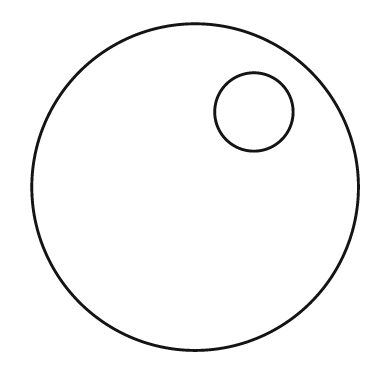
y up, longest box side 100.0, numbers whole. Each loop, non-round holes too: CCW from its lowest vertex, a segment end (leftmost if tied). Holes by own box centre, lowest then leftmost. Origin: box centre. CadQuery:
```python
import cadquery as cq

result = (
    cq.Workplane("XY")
    .moveTo(0.0, 0.0)
    .circle(50.0)
    .moveTo(18.0, 23.0)
    .circle(12.0)
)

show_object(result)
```